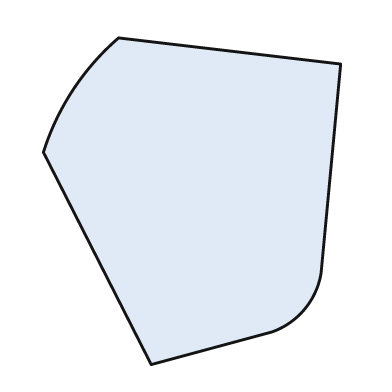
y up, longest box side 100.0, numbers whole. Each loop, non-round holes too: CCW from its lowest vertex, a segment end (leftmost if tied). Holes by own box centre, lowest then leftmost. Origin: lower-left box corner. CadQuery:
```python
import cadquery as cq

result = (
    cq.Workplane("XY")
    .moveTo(33.0, 0.0)
    .lineTo(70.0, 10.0)
    .threePointArc((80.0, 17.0), (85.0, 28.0))
    .lineTo(91.0, 92.0)
    .lineTo(23.0, 100.0)
    .threePointArc((9.0, 84.0), (0.0, 65.0))
    .close()
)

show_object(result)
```